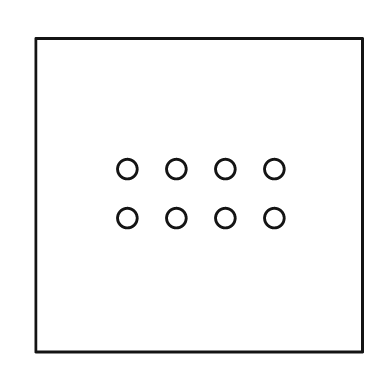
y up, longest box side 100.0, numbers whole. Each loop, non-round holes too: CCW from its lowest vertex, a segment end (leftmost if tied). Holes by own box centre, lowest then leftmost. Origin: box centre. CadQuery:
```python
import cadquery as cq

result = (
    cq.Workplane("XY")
    .moveTo(-50.0, -48.0)
    .lineTo(50.0, -48.0)
    .lineTo(50.0, 48.0)
    .lineTo(-50.0, 48.0)
    .close()
    .moveTo(-22.0, -7.0)
    .circle(3.0)
    .moveTo(-7.0, -7.0)
    .circle(3.0)
    .moveTo(8.0, -7.0)
    .circle(3.0)
    .moveTo(23.0, -7.0)
    .circle(3.0)
    .moveTo(-22.0, 8.0)
    .circle(3.0)
    .moveTo(-7.0, 8.0)
    .circle(3.0)
    .moveTo(8.0, 8.0)
    .circle(3.0)
    .moveTo(23.0, 8.0)
    .circle(3.0)
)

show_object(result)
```